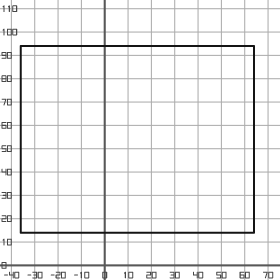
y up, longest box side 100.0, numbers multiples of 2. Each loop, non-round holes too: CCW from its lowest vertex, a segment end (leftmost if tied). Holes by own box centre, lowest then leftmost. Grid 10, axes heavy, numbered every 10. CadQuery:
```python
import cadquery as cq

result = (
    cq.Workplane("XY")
    .moveTo(-36.0, 14.0)
    .lineTo(64.0, 14.0)
    .lineTo(64.0, 94.0)
    .lineTo(-36.0, 94.0)
    .close()
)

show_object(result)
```